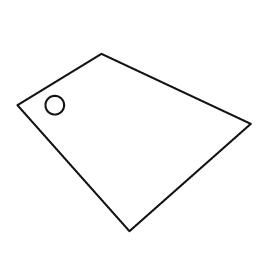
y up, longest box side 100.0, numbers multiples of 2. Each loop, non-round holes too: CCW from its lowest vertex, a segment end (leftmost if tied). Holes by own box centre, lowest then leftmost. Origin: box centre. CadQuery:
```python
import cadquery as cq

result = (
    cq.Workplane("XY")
    .moveTo(-2.0, -38.0)
    .lineTo(50.0, 8.0)
    .lineTo(-14.0, 38.0)
    .lineTo(-50.0, 16.0)
    .close()
    .moveTo(-34.0, 16.0)
    .circle(4.0)
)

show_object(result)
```